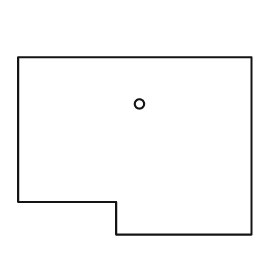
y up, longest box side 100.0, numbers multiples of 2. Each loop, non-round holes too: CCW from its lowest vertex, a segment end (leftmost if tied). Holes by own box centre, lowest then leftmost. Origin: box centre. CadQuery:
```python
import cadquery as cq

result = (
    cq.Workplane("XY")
    .moveTo(-8.0, -38.0)
    .lineTo(50.0, -38.0)
    .lineTo(50.0, 38.0)
    .lineTo(-50.0, 38.0)
    .lineTo(-50.0, -24.0)
    .lineTo(-8.0, -24.0)
    .close()
    .moveTo(2.0, 18.0)
    .circle(2.0)
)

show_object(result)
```